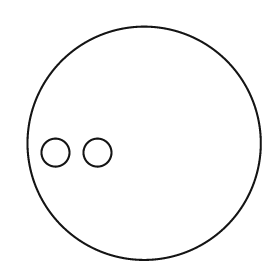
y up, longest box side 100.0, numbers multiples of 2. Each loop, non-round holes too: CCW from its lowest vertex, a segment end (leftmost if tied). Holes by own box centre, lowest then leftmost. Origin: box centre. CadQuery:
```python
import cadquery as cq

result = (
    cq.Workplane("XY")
    .moveTo(0.0, 0.0)
    .circle(50.0)
    .moveTo(-38.0, -4.0)
    .circle(6.0)
    .moveTo(-20.0, -4.0)
    .circle(6.0)
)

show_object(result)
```